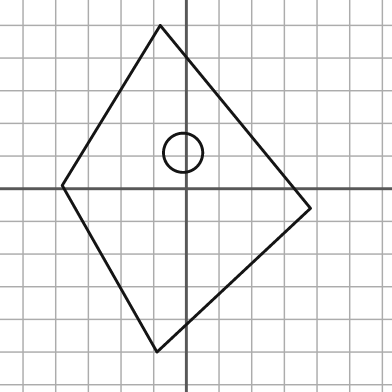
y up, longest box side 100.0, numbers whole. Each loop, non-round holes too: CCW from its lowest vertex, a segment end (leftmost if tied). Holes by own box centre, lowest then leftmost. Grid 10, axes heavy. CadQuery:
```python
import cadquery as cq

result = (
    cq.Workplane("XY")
    .moveTo(-9.0, -50.0)
    .lineTo(38.0, -6.0)
    .lineTo(-8.0, 50.0)
    .lineTo(-38.0, 1.0)
    .close()
    .moveTo(-1.0, 11.0)
    .circle(6.0)
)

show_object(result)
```